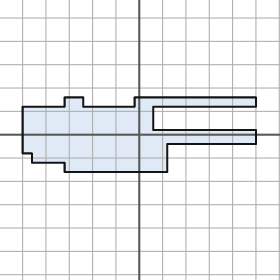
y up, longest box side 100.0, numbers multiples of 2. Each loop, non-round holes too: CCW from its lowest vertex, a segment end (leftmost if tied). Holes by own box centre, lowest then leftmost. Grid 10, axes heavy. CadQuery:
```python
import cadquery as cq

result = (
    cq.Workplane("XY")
    .moveTo(-32.0, -16.0)
    .lineTo(12.0, -16.0)
    .lineTo(12.0, -4.0)
    .lineTo(50.0, -4.0)
    .lineTo(50.0, 2.0)
    .lineTo(6.0, 2.0)
    .lineTo(6.0, 12.0)
    .lineTo(50.0, 12.0)
    .lineTo(50.0, 16.0)
    .lineTo(-2.0, 16.0)
    .lineTo(-2.0, 12.0)
    .lineTo(-24.0, 12.0)
    .lineTo(-24.0, 16.0)
    .lineTo(-32.0, 16.0)
    .lineTo(-32.0, 12.0)
    .lineTo(-50.0, 12.0)
    .lineTo(-50.0, -8.0)
    .lineTo(-46.0, -8.0)
    .lineTo(-46.0, -12.0)
    .lineTo(-32.0, -12.0)
    .close()
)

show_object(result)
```